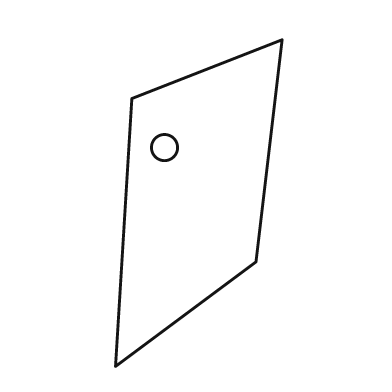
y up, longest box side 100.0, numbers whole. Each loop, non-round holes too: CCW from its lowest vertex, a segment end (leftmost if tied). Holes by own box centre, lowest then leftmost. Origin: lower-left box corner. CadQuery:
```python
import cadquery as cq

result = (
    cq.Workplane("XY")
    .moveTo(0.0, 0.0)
    .lineTo(43.0, 32.0)
    .lineTo(51.0, 100.0)
    .lineTo(5.0, 82.0)
    .close()
    .moveTo(15.0, 67.0)
    .circle(4.0)
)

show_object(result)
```